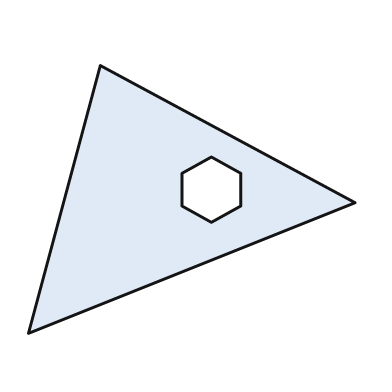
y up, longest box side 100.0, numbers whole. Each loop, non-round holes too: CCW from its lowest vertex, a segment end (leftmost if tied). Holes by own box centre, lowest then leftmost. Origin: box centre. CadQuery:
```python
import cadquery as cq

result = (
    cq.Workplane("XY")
    .moveTo(-50.0, -41.0)
    .lineTo(50.0, -1.0)
    .lineTo(-28.0, 41.0)
    .close()
    .moveTo(6.0, -7.0)
    .lineTo(15.0, -2.0)
    .lineTo(15.0, 8.0)
    .lineTo(6.0, 13.0)
    .lineTo(-3.0, 8.0)
    .lineTo(-3.0, -2.0)
    .close()
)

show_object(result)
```